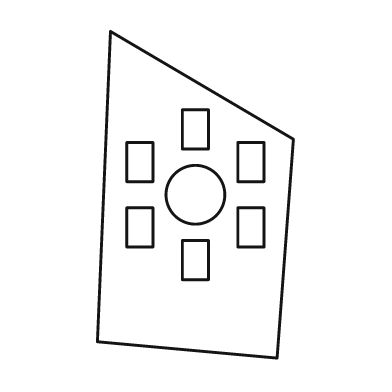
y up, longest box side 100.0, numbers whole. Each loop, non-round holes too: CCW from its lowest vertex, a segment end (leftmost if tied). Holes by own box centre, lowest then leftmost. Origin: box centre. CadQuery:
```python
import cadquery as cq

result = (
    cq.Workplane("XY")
    .moveTo(25.0, -50.0)
    .lineTo(30.0, 17.0)
    .lineTo(-26.0, 50.0)
    .lineTo(-30.0, -45.0)
    .close()
    .moveTo(-4.0, -26.0)
    .lineTo(4.0, -26.0)
    .lineTo(4.0, -14.0)
    .lineTo(-4.0, -14.0)
    .close()
    .moveTo(-21.0, -16.0)
    .lineTo(-13.0, -16.0)
    .lineTo(-13.0, -4.0)
    .lineTo(-21.0, -4.0)
    .close()
    .moveTo(13.0, -16.0)
    .lineTo(21.0, -16.0)
    .lineTo(21.0, -4.0)
    .lineTo(13.0, -4.0)
    .close()
    .moveTo(0.0, 0.0)
    .circle(9.0)
    .moveTo(-21.0, 4.0)
    .lineTo(-13.0, 4.0)
    .lineTo(-13.0, 16.0)
    .lineTo(-21.0, 16.0)
    .close()
    .moveTo(13.0, 4.0)
    .lineTo(21.0, 4.0)
    .lineTo(21.0, 16.0)
    .lineTo(13.0, 16.0)
    .close()
    .moveTo(-4.0, 14.0)
    .lineTo(4.0, 14.0)
    .lineTo(4.0, 26.0)
    .lineTo(-4.0, 26.0)
    .close()
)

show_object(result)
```